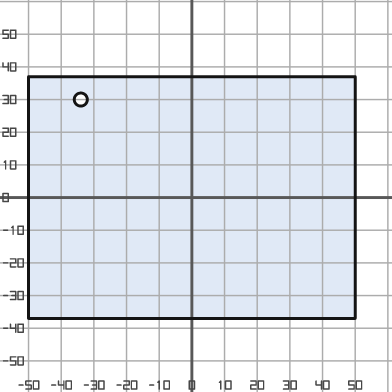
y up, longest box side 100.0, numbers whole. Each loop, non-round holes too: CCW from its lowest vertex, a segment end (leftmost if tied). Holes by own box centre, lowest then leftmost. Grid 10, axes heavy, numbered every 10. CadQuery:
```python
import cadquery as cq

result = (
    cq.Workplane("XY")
    .moveTo(-50.0, -37.0)
    .lineTo(50.0, -37.0)
    .lineTo(50.0, 37.0)
    .lineTo(-50.0, 37.0)
    .close()
    .moveTo(-34.0, 30.0)
    .circle(2.0)
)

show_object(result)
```